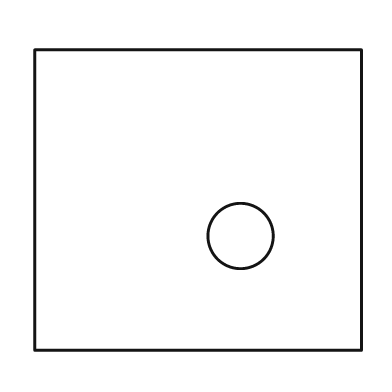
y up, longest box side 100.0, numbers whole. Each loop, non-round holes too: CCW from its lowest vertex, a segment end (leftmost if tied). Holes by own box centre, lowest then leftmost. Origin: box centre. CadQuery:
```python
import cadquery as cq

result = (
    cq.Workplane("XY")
    .moveTo(-50.0, -46.0)
    .lineTo(50.0, -46.0)
    .lineTo(50.0, 46.0)
    .lineTo(-50.0, 46.0)
    .close()
    .moveTo(13.0, -11.0)
    .circle(10.0)
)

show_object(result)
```